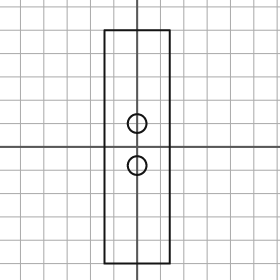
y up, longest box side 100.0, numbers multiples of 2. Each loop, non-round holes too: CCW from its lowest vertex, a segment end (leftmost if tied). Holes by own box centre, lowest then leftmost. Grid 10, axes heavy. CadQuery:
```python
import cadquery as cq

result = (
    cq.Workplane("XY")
    .moveTo(-14.0, -50.0)
    .lineTo(14.0, -50.0)
    .lineTo(14.0, 50.0)
    .lineTo(-14.0, 50.0)
    .close()
    .moveTo(0.0, -8.0)
    .circle(4.0)
    .moveTo(0.0, 10.0)
    .circle(4.0)
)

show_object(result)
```